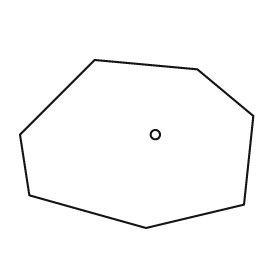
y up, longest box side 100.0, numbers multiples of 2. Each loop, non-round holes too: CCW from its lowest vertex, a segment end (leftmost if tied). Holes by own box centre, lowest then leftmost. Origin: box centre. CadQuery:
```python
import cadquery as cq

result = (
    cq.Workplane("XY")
    .moveTo(4.0, -36.0)
    .lineTo(46.0, -26.0)
    .lineTo(50.0, 12.0)
    .lineTo(26.0, 32.0)
    .lineTo(-18.0, 36.0)
    .lineTo(-50.0, 4.0)
    .lineTo(-46.0, -22.0)
    .close()
    .moveTo(8.0, 4.0)
    .circle(2.0)
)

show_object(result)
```